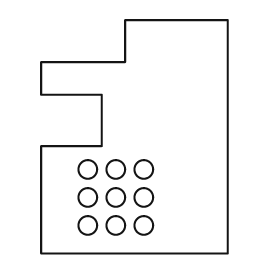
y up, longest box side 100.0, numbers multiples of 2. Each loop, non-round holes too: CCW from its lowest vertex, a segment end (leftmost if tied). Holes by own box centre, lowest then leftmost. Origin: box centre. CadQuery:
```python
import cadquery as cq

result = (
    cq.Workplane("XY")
    .moveTo(-40.0, -50.0)
    .lineTo(40.0, -50.0)
    .lineTo(40.0, 50.0)
    .lineTo(-4.0, 50.0)
    .lineTo(-4.0, 32.0)
    .lineTo(-40.0, 32.0)
    .lineTo(-40.0, 18.0)
    .lineTo(-14.0, 18.0)
    .lineTo(-14.0, -4.0)
    .lineTo(-40.0, -4.0)
    .close()
    .moveTo(-20.0, -38.0)
    .circle(4.0)
    .moveTo(-8.0, -38.0)
    .circle(4.0)
    .moveTo(4.0, -38.0)
    .circle(4.0)
    .moveTo(-20.0, -26.0)
    .circle(4.0)
    .moveTo(-8.0, -26.0)
    .circle(4.0)
    .moveTo(4.0, -26.0)
    .circle(4.0)
    .moveTo(-20.0, -14.0)
    .circle(4.0)
    .moveTo(-8.0, -14.0)
    .circle(4.0)
    .moveTo(4.0, -14.0)
    .circle(4.0)
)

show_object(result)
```